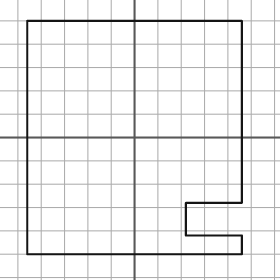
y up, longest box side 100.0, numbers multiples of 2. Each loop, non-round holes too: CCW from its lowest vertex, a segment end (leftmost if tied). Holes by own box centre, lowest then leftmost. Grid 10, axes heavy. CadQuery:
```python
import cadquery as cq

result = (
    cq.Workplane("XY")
    .moveTo(-46.0, -50.0)
    .lineTo(46.0, -50.0)
    .lineTo(46.0, -42.0)
    .lineTo(22.0, -42.0)
    .lineTo(22.0, -28.0)
    .lineTo(46.0, -28.0)
    .lineTo(46.0, 50.0)
    .lineTo(-46.0, 50.0)
    .close()
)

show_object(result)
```